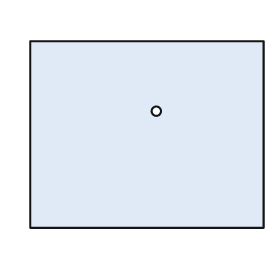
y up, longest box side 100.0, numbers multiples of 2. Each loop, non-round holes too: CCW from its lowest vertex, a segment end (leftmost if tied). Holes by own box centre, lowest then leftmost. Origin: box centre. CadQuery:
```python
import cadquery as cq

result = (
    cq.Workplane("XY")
    .moveTo(-50.0, -40.0)
    .lineTo(50.0, -40.0)
    .lineTo(50.0, 40.0)
    .lineTo(-50.0, 40.0)
    .close()
    .moveTo(4.0, 10.0)
    .circle(2.0)
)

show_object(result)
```